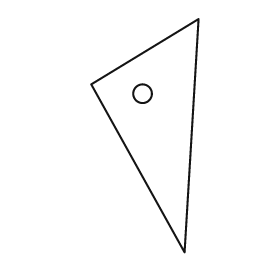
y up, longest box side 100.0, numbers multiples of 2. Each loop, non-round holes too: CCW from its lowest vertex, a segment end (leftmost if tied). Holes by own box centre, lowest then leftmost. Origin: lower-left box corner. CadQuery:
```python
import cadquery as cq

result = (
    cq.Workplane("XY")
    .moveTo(40.0, 0.0)
    .lineTo(46.0, 100.0)
    .lineTo(0.0, 72.0)
    .close()
    .moveTo(22.0, 68.0)
    .circle(4.0)
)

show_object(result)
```